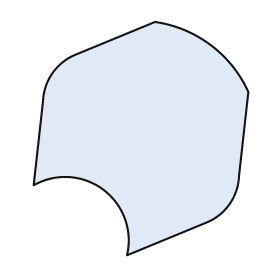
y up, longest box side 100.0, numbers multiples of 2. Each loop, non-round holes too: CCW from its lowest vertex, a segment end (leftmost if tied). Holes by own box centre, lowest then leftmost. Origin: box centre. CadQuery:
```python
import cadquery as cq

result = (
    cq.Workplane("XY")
    .moveTo(-6.0, -50.0)
    .lineTo(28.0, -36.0)
    .threePointArc((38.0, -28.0), (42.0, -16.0))
    .lineTo(46.0, 20.0)
    .threePointArc((30.0, 40.0), (6.0, 50.0))
    .lineTo(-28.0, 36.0)
    .threePointArc((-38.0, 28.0), (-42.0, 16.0))
    .lineTo(-46.0, -20.0)
    .threePointArc((-16.0, -22.0), (-6.0, -50.0))
    .close()
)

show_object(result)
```